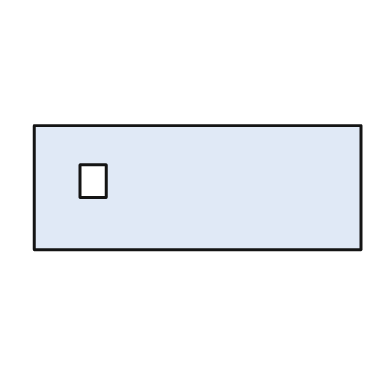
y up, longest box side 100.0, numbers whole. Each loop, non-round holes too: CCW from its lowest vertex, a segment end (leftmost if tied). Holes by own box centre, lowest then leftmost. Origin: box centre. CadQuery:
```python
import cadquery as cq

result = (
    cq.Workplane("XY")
    .moveTo(-50.0, -19.0)
    .lineTo(50.0, -19.0)
    .lineTo(50.0, 19.0)
    .lineTo(-50.0, 19.0)
    .close()
    .moveTo(-36.0, -3.0)
    .lineTo(-28.0, -3.0)
    .lineTo(-28.0, 7.0)
    .lineTo(-36.0, 7.0)
    .close()
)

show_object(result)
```